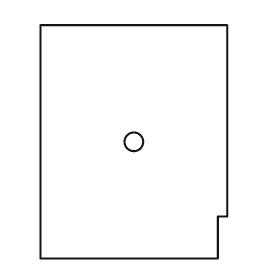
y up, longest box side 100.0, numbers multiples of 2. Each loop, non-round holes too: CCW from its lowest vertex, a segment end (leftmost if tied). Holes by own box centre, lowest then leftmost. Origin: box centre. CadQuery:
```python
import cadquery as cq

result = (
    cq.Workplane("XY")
    .moveTo(-40.0, -50.0)
    .lineTo(36.0, -50.0)
    .lineTo(36.0, -32.0)
    .lineTo(40.0, -32.0)
    .lineTo(40.0, 50.0)
    .lineTo(-40.0, 50.0)
    .close()
    .moveTo(0.0, 0.0)
    .circle(4.0)
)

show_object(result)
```